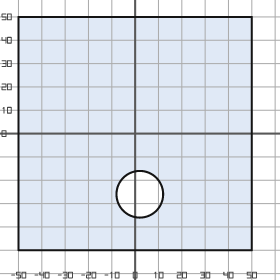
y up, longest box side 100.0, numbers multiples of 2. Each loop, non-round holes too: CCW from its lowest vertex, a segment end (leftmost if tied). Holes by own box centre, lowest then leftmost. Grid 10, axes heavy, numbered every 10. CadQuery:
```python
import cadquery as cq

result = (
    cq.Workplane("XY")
    .moveTo(-50.0, -50.0)
    .lineTo(50.0, -50.0)
    .lineTo(50.0, 50.0)
    .lineTo(-50.0, 50.0)
    .close()
    .moveTo(2.0, -26.0)
    .circle(10.0)
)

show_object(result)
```